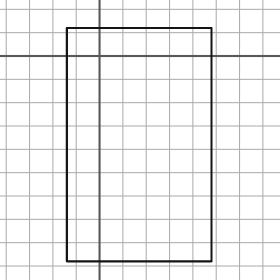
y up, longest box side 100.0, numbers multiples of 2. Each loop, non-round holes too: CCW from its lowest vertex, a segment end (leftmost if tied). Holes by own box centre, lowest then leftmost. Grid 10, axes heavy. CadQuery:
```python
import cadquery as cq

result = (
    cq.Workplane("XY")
    .moveTo(-14.0, -88.0)
    .lineTo(48.0, -88.0)
    .lineTo(48.0, 12.0)
    .lineTo(-14.0, 12.0)
    .close()
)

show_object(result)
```